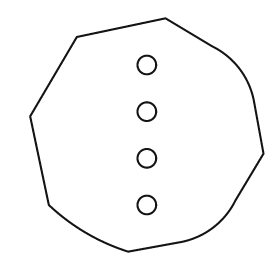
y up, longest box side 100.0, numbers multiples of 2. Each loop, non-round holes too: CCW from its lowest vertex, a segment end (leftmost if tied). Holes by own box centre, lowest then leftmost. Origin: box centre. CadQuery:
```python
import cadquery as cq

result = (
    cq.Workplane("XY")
    .moveTo(-8.0, -50.0)
    .lineTo(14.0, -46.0)
    .threePointArc((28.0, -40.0), (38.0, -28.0))
    .lineTo(50.0, -8.0)
    .lineTo(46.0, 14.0)
    .threePointArc((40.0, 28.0), (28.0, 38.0))
    .lineTo(8.0, 50.0)
    .lineTo(-30.0, 42.0)
    .lineTo(-50.0, 8.0)
    .lineTo(-42.0, -30.0)
    .threePointArc((-26.0, -42.0), (-8.0, -50.0))
    .close()
    .moveTo(0.0, -30.0)
    .circle(4.0)
    .moveTo(0.0, -10.0)
    .circle(4.0)
    .moveTo(0.0, 10.0)
    .circle(4.0)
    .moveTo(0.0, 30.0)
    .circle(4.0)
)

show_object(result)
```